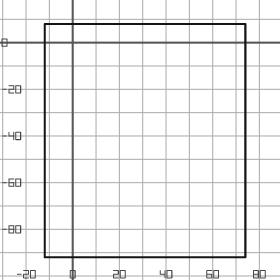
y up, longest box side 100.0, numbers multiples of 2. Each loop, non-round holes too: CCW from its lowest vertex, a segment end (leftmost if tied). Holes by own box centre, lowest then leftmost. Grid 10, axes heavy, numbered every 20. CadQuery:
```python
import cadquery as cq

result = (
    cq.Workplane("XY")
    .moveTo(-12.0, -92.0)
    .lineTo(74.0, -92.0)
    .lineTo(74.0, 8.0)
    .lineTo(-12.0, 8.0)
    .close()
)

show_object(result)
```